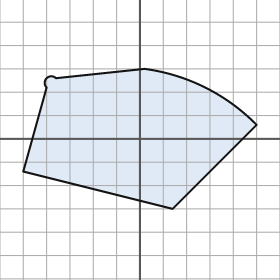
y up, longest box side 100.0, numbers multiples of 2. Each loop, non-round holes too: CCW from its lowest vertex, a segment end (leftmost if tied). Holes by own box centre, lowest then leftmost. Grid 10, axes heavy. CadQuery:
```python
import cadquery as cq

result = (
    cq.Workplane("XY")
    .moveTo(14.0, -30.0)
    .lineTo(50.0, 6.0)
    .threePointArc((28.0, 22.0), (2.0, 30.0))
    .lineTo(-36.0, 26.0)
    .threePointArc((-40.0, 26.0), (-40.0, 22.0))
    .lineTo(-50.0, -14.0)
    .close()
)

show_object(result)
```